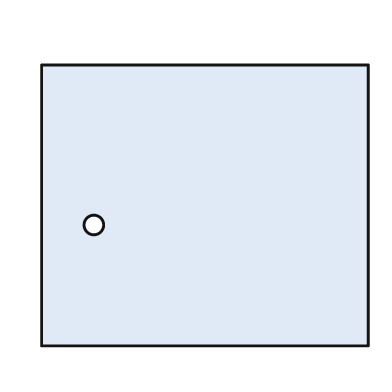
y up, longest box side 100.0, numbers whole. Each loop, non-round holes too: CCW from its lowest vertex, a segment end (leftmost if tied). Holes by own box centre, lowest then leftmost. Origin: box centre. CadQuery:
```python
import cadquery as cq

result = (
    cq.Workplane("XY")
    .moveTo(-50.0, -43.0)
    .lineTo(50.0, -43.0)
    .lineTo(50.0, 43.0)
    .lineTo(-50.0, 43.0)
    .close()
    .moveTo(-34.0, -6.0)
    .circle(3.0)
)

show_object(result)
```